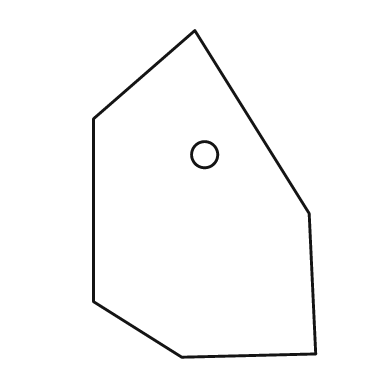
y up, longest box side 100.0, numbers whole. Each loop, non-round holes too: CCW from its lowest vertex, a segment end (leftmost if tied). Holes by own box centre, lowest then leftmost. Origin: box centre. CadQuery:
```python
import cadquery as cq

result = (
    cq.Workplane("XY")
    .moveTo(-7.0, -50.0)
    .lineTo(34.0, -49.0)
    .lineTo(32.0, -6.0)
    .lineTo(-3.0, 50.0)
    .lineTo(-34.0, 23.0)
    .lineTo(-34.0, -33.0)
    .close()
    .moveTo(0.0, 12.0)
    .circle(4.0)
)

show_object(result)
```